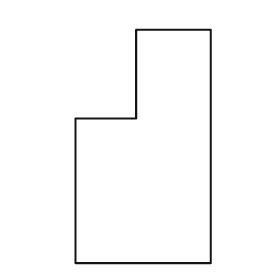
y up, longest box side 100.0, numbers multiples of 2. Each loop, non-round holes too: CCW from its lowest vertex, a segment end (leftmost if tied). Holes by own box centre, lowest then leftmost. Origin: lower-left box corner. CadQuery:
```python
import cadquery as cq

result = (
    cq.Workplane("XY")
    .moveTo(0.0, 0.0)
    .lineTo(58.0, 0.0)
    .lineTo(58.0, 100.0)
    .lineTo(26.0, 100.0)
    .lineTo(26.0, 62.0)
    .lineTo(0.0, 62.0)
    .close()
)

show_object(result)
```